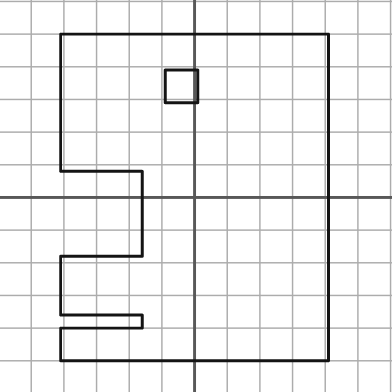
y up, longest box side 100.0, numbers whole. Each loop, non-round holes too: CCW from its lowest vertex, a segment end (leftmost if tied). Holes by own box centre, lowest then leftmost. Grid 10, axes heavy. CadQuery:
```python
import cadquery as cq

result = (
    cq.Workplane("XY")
    .moveTo(-41.0, -50.0)
    .lineTo(41.0, -50.0)
    .lineTo(41.0, 50.0)
    .lineTo(-41.0, 50.0)
    .lineTo(-41.0, 8.0)
    .lineTo(-16.0, 8.0)
    .lineTo(-16.0, -18.0)
    .lineTo(-41.0, -18.0)
    .lineTo(-41.0, -36.0)
    .lineTo(-16.0, -36.0)
    .lineTo(-16.0, -40.0)
    .lineTo(-41.0, -40.0)
    .close()
    .moveTo(-9.0, 29.0)
    .lineTo(1.0, 29.0)
    .lineTo(1.0, 39.0)
    .lineTo(-9.0, 39.0)
    .close()
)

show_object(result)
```